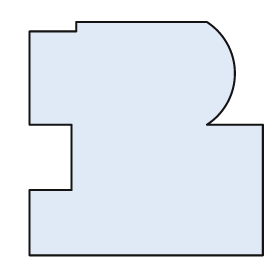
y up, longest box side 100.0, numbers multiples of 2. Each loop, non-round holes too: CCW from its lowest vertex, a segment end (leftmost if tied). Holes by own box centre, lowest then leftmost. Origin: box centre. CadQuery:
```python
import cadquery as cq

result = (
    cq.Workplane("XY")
    .moveTo(-50.0, -50.0)
    .lineTo(50.0, -50.0)
    .lineTo(50.0, 6.0)
    .lineTo(26.0, 6.0)
    .threePointArc((38.0, 28.0), (26.0, 50.0))
    .lineTo(-30.0, 50.0)
    .lineTo(-30.0, 46.0)
    .lineTo(-50.0, 46.0)
    .lineTo(-50.0, 6.0)
    .lineTo(-32.0, 6.0)
    .lineTo(-32.0, -22.0)
    .lineTo(-50.0, -22.0)
    .close()
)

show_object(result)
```